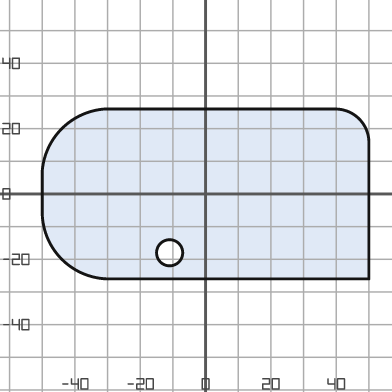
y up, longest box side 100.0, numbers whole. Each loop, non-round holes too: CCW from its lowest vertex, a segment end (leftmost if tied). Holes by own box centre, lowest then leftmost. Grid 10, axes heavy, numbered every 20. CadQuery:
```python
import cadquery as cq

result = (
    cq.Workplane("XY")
    .moveTo(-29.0, -26.0)
    .lineTo(50.0, -26.0)
    .lineTo(50.0, 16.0)
    .threePointArc((47.0, 23.0), (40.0, 26.0))
    .lineTo(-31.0, 26.0)
    .threePointArc((-44.0, 20.0), (-50.0, 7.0))
    .lineTo(-50.0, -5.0)
    .threePointArc((-44.0, -20.0), (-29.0, -26.0))
    .close()
    .moveTo(-11.0, -18.0)
    .circle(4.0)
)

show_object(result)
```